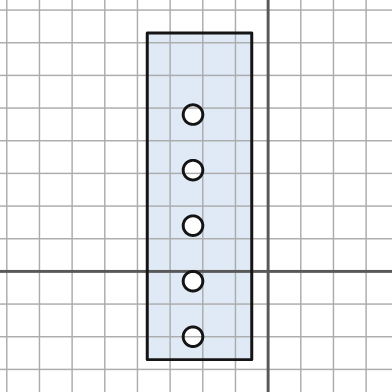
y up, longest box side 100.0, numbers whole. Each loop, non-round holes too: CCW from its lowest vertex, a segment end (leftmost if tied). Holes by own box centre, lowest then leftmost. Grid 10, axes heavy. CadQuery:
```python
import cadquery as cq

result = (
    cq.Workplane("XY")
    .moveTo(-37.0, -27.0)
    .lineTo(-5.0, -27.0)
    .lineTo(-5.0, 73.0)
    .lineTo(-37.0, 73.0)
    .close()
    .moveTo(-23.0, -20.0)
    .circle(3.0)
    .moveTo(-23.0, -3.0)
    .circle(3.0)
    .moveTo(-23.0, 14.0)
    .circle(3.0)
    .moveTo(-23.0, 31.0)
    .circle(3.0)
    .moveTo(-23.0, 48.0)
    .circle(3.0)
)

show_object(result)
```